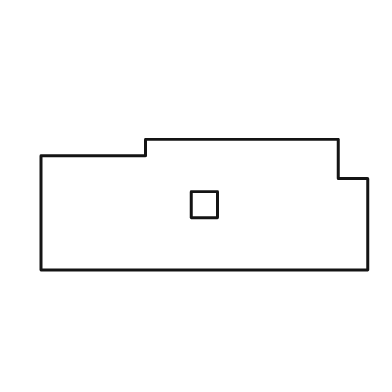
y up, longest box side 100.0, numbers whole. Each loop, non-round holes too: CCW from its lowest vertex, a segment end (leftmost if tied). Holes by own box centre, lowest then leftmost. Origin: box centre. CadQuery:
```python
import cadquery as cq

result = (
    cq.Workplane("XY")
    .moveTo(-50.0, -20.0)
    .lineTo(50.0, -20.0)
    .lineTo(50.0, 8.0)
    .lineTo(41.0, 8.0)
    .lineTo(41.0, 20.0)
    .lineTo(-18.0, 20.0)
    .lineTo(-18.0, 15.0)
    .lineTo(-50.0, 15.0)
    .close()
    .moveTo(-4.0, -4.0)
    .lineTo(4.0, -4.0)
    .lineTo(4.0, 4.0)
    .lineTo(-4.0, 4.0)
    .close()
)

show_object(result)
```